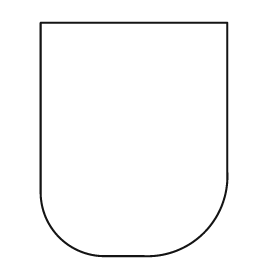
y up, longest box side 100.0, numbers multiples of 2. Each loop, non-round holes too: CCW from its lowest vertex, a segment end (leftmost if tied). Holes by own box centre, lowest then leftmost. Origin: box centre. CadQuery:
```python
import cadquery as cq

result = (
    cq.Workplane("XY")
    .moveTo(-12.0, -50.0)
    .lineTo(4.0, -50.0)
    .threePointArc((30.0, -40.0), (40.0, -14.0))
    .lineTo(40.0, 50.0)
    .lineTo(-40.0, 50.0)
    .lineTo(-40.0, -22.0)
    .threePointArc((-32.0, -42.0), (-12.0, -50.0))
    .close()
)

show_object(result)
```